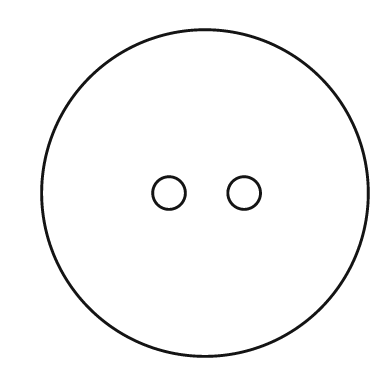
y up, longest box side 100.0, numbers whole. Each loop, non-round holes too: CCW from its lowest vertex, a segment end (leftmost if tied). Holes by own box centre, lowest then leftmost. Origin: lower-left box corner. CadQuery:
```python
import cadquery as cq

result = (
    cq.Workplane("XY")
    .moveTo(50.0, 50.0)
    .circle(50.0)
    .moveTo(39.0, 50.0)
    .circle(5.0)
    .moveTo(62.0, 50.0)
    .circle(5.0)
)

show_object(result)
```